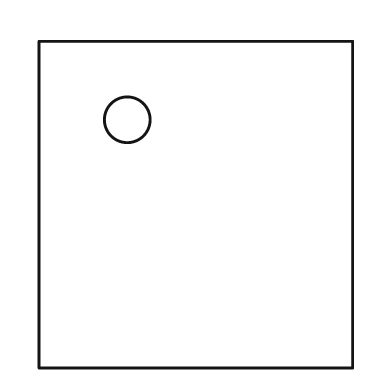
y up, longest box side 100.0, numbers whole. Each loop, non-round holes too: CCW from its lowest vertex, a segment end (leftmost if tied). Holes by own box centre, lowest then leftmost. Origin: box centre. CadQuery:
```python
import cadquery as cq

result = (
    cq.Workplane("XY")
    .moveTo(-48.0, -50.0)
    .lineTo(48.0, -50.0)
    .lineTo(48.0, 50.0)
    .lineTo(-48.0, 50.0)
    .close()
    .moveTo(-21.0, 26.0)
    .circle(7.0)
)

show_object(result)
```